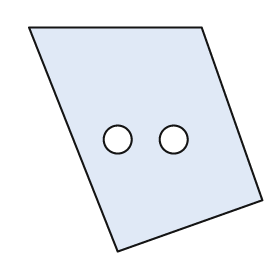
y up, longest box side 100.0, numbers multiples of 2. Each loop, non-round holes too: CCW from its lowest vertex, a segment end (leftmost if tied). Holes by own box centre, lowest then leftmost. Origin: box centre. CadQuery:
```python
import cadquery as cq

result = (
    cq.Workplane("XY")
    .moveTo(-12.0, -48.0)
    .lineTo(50.0, -26.0)
    .lineTo(24.0, 48.0)
    .lineTo(-50.0, 48.0)
    .close()
    .moveTo(-12.0, 0.0)
    .circle(6.0)
    .moveTo(12.0, 0.0)
    .circle(6.0)
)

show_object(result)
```